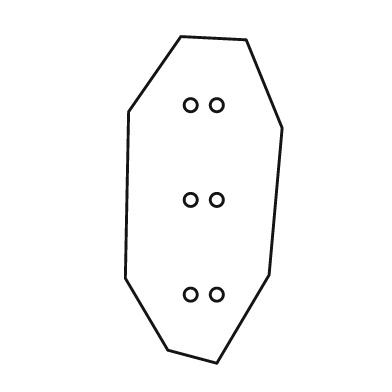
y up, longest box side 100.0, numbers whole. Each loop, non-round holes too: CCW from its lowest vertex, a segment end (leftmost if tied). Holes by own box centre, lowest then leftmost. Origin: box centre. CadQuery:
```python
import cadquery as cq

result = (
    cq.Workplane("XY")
    .moveTo(4.0, -50.0)
    .lineTo(20.0, -23.0)
    .lineTo(24.0, 22.0)
    .lineTo(13.0, 49.0)
    .lineTo(-7.0, 50.0)
    .lineTo(-23.0, 27.0)
    .lineTo(-24.0, -24.0)
    .lineTo(-11.0, -46.0)
    .close()
    .moveTo(-4.0, -29.0)
    .circle(2.0)
    .moveTo(4.0, -29.0)
    .circle(2.0)
    .moveTo(-4.0, 0.0)
    .circle(2.0)
    .moveTo(4.0, 0.0)
    .circle(2.0)
    .moveTo(-4.0, 29.0)
    .circle(2.0)
    .moveTo(4.0, 29.0)
    .circle(2.0)
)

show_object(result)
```